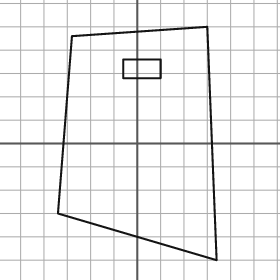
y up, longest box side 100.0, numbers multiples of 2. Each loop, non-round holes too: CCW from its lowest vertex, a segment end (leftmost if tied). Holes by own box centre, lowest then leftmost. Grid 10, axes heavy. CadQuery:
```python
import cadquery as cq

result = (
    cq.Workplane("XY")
    .moveTo(34.0, -50.0)
    .lineTo(30.0, 50.0)
    .lineTo(-28.0, 46.0)
    .lineTo(-34.0, -30.0)
    .close()
    .moveTo(-6.0, 28.0)
    .lineTo(10.0, 28.0)
    .lineTo(10.0, 36.0)
    .lineTo(-6.0, 36.0)
    .close()
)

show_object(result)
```